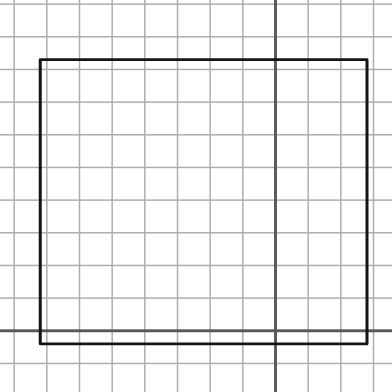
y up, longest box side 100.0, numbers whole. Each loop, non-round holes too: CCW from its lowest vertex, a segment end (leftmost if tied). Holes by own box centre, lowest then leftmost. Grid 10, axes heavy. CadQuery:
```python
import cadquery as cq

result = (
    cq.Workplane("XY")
    .moveTo(-72.0, -4.0)
    .lineTo(28.0, -4.0)
    .lineTo(28.0, 83.0)
    .lineTo(-72.0, 83.0)
    .close()
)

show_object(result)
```